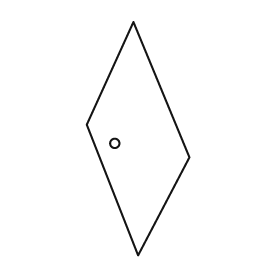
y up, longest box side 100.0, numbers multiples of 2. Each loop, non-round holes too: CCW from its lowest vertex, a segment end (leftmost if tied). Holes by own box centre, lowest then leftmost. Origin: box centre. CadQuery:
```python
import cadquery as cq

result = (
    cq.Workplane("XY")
    .moveTo(0.0, -50.0)
    .lineTo(22.0, -8.0)
    .lineTo(-2.0, 50.0)
    .lineTo(-22.0, 6.0)
    .close()
    .moveTo(-10.0, -2.0)
    .circle(2.0)
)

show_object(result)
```